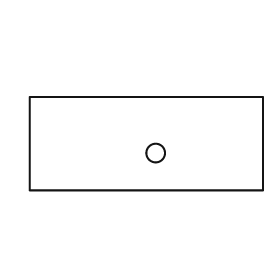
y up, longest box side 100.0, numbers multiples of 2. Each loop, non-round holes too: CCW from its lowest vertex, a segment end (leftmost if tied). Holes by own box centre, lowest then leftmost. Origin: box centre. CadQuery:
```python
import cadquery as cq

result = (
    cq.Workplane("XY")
    .moveTo(-50.0, -20.0)
    .lineTo(50.0, -20.0)
    .lineTo(50.0, 20.0)
    .lineTo(-50.0, 20.0)
    .close()
    .moveTo(4.0, -4.0)
    .circle(4.0)
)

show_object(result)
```